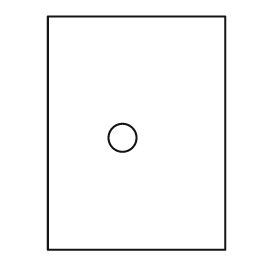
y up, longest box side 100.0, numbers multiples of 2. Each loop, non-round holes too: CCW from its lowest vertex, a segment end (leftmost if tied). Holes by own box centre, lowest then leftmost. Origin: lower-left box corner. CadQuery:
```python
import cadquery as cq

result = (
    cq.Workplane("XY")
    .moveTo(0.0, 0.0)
    .lineTo(76.0, 0.0)
    .lineTo(76.0, 100.0)
    .lineTo(0.0, 100.0)
    .close()
    .moveTo(32.0, 48.0)
    .circle(6.0)
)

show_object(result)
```